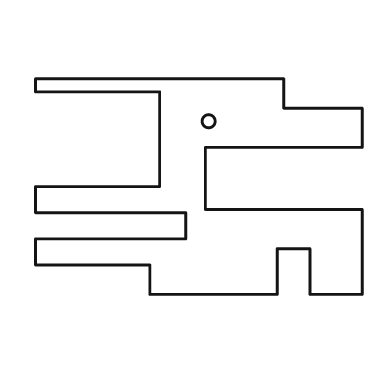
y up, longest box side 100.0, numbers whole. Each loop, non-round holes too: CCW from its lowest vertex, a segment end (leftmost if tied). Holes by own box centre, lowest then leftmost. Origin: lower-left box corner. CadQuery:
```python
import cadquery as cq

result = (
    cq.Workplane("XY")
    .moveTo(35.0, 0.0)
    .lineTo(74.0, 0.0)
    .lineTo(74.0, 14.0)
    .lineTo(84.0, 14.0)
    .lineTo(84.0, 0.0)
    .lineTo(100.0, 0.0)
    .lineTo(100.0, 26.0)
    .lineTo(52.0, 26.0)
    .lineTo(52.0, 45.0)
    .lineTo(100.0, 45.0)
    .lineTo(100.0, 57.0)
    .lineTo(76.0, 57.0)
    .lineTo(76.0, 66.0)
    .lineTo(0.0, 66.0)
    .lineTo(0.0, 62.0)
    .lineTo(38.0, 62.0)
    .lineTo(38.0, 33.0)
    .lineTo(0.0, 33.0)
    .lineTo(0.0, 25.0)
    .lineTo(46.0, 25.0)
    .lineTo(46.0, 17.0)
    .lineTo(0.0, 17.0)
    .lineTo(0.0, 9.0)
    .lineTo(35.0, 9.0)
    .close()
    .moveTo(53.0, 53.0)
    .circle(2.0)
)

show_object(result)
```